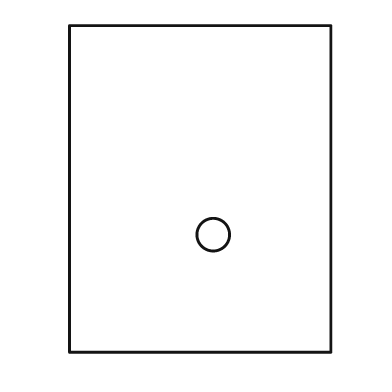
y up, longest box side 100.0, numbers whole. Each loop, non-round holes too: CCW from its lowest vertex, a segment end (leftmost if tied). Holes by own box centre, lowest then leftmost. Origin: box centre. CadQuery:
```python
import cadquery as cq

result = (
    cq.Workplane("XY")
    .moveTo(-40.0, -50.0)
    .lineTo(40.0, -50.0)
    .lineTo(40.0, 50.0)
    .lineTo(-40.0, 50.0)
    .close()
    .moveTo(4.0, -14.0)
    .circle(5.0)
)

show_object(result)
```